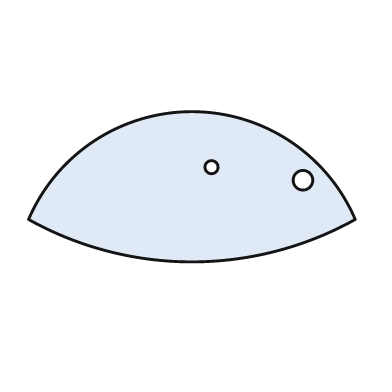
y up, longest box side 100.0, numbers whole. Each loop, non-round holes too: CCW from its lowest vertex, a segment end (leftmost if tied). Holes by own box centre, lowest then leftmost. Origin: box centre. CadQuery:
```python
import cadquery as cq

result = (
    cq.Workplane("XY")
    .moveTo(-50.0, -10.0)
    .threePointArc((0.0, -23.0), (50.0, -10.0))
    .threePointArc((0.0, 23.0), (-50.0, -10.0))
    .close()
    .moveTo(34.0, 2.0)
    .circle(3.0)
    .moveTo(6.0, 6.0)
    .circle(2.0)
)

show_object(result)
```